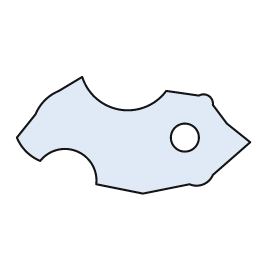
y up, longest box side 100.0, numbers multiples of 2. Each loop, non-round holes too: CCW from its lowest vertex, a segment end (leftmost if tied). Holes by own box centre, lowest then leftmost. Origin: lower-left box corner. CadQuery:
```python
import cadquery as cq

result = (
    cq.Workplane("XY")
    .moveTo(54.0, 0.0)
    .lineTo(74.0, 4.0)
    .threePointArc((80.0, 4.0), (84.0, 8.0))
    .lineTo(100.0, 22.0)
    .lineTo(90.0, 30.0)
    .lineTo(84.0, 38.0)
    .threePointArc((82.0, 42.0), (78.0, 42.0))
    .lineTo(64.0, 44.0)
    .threePointArc((44.0, 36.0), (28.0, 50.0))
    .lineTo(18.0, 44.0)
    .threePointArc((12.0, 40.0), (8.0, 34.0))
    .lineTo(0.0, 24.0)
    .threePointArc((4.0, 18.0), (10.0, 14.0))
    .threePointArc((26.0, 18.0), (34.0, 4.0))
    .close()
    .moveTo(72.0, 24.0)
    .circle(6.0)
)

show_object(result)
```